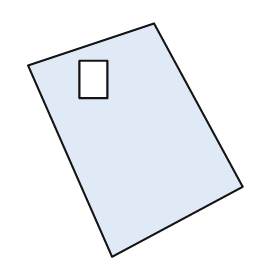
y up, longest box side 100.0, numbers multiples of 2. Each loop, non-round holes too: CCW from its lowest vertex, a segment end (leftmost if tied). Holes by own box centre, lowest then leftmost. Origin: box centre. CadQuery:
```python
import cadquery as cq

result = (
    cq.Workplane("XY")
    .moveTo(-10.0, -50.0)
    .lineTo(46.0, -20.0)
    .lineTo(8.0, 50.0)
    .lineTo(-46.0, 32.0)
    .close()
    .moveTo(-24.0, 18.0)
    .lineTo(-12.0, 18.0)
    .lineTo(-12.0, 34.0)
    .lineTo(-24.0, 34.0)
    .close()
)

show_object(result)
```